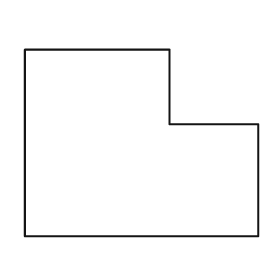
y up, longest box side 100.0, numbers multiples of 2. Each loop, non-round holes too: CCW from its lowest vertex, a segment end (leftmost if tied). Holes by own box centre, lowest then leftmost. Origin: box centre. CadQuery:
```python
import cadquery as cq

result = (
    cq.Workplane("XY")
    .moveTo(-50.0, -40.0)
    .lineTo(50.0, -40.0)
    .lineTo(50.0, 8.0)
    .lineTo(12.0, 8.0)
    .lineTo(12.0, 40.0)
    .lineTo(-50.0, 40.0)
    .close()
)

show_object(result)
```